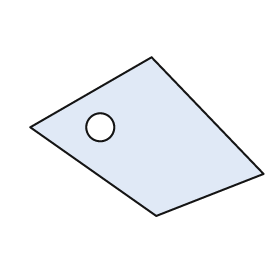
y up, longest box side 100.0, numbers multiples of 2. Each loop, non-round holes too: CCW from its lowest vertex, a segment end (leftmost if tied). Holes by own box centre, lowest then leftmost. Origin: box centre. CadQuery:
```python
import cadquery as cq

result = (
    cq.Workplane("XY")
    .moveTo(4.0, -34.0)
    .lineTo(50.0, -16.0)
    .lineTo(2.0, 34.0)
    .lineTo(-50.0, 4.0)
    .close()
    .moveTo(-20.0, 4.0)
    .circle(6.0)
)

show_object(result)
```